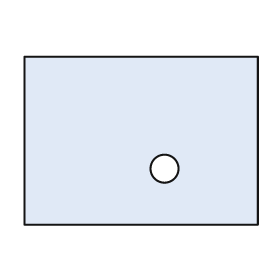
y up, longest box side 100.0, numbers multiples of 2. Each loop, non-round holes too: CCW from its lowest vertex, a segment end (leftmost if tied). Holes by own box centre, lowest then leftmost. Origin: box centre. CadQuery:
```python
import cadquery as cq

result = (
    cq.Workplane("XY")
    .moveTo(-50.0, -36.0)
    .lineTo(50.0, -36.0)
    .lineTo(50.0, 36.0)
    .lineTo(-50.0, 36.0)
    .close()
    .moveTo(10.0, -12.0)
    .circle(6.0)
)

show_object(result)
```